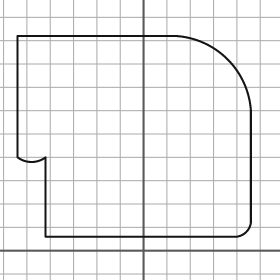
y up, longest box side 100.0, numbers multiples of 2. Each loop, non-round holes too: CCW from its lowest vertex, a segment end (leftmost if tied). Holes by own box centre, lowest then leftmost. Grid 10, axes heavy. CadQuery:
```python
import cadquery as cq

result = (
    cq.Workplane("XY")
    .moveTo(-42.0, 6.0)
    .lineTo(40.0, 6.0)
    .threePointArc((44.0, 8.0), (46.0, 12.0))
    .lineTo(46.0, 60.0)
    .threePointArc((36.0, 82.0), (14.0, 92.0))
    .lineTo(-54.0, 92.0)
    .lineTo(-54.0, 40.0)
    .threePointArc((-48.0, 38.0), (-42.0, 40.0))
    .close()
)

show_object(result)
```